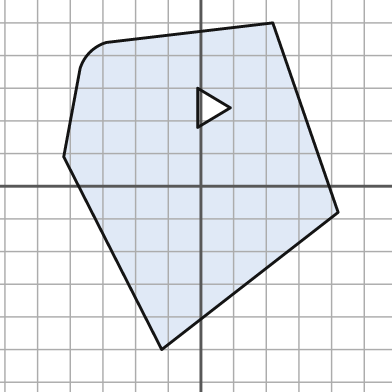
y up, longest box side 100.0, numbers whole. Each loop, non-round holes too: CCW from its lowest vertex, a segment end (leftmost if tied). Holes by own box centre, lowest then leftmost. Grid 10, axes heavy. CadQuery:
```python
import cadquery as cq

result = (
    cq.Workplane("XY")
    .moveTo(-12.0, -50.0)
    .lineTo(42.0, -8.0)
    .lineTo(22.0, 50.0)
    .lineTo(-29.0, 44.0)
    .threePointArc((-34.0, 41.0), (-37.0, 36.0))
    .lineTo(-42.0, 9.0)
    .close()
    .moveTo(-1.0, 18.0)
    .lineTo(9.0, 24.0)
    .lineTo(-1.0, 30.0)
    .close()
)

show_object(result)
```